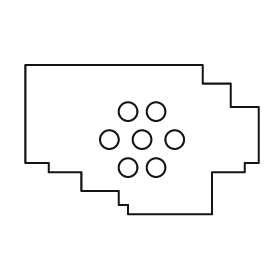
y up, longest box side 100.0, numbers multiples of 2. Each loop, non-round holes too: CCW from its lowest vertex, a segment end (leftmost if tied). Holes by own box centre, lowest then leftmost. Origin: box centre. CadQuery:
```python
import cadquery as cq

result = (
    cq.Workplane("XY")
    .moveTo(-6.0, -32.0)
    .lineTo(30.0, -32.0)
    .lineTo(30.0, -14.0)
    .lineTo(44.0, -14.0)
    .lineTo(44.0, -10.0)
    .lineTo(50.0, -10.0)
    .lineTo(50.0, 14.0)
    .lineTo(38.0, 14.0)
    .lineTo(38.0, 24.0)
    .lineTo(26.0, 24.0)
    .lineTo(26.0, 32.0)
    .lineTo(-50.0, 32.0)
    .lineTo(-50.0, -10.0)
    .lineTo(-40.0, -10.0)
    .lineTo(-40.0, -14.0)
    .lineTo(-26.0, -14.0)
    .lineTo(-26.0, -22.0)
    .lineTo(-10.0, -22.0)
    .lineTo(-10.0, -28.0)
    .lineTo(-6.0, -28.0)
    .close()
    .moveTo(-6.0, -12.0)
    .circle(4.0)
    .moveTo(6.0, -12.0)
    .circle(4.0)
    .moveTo(-14.0, 0.0)
    .circle(4.0)
    .moveTo(0.0, 0.0)
    .circle(4.0)
    .moveTo(14.0, 0.0)
    .circle(4.0)
    .moveTo(-6.0, 12.0)
    .circle(4.0)
    .moveTo(6.0, 12.0)
    .circle(4.0)
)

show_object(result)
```